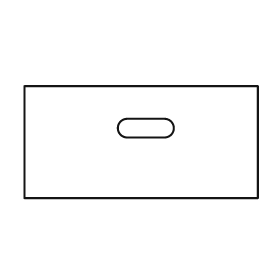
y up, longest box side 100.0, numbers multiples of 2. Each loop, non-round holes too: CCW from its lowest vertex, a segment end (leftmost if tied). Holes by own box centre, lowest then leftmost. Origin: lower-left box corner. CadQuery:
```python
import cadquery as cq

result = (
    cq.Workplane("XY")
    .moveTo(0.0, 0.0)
    .lineTo(100.0, 0.0)
    .lineTo(100.0, 48.0)
    .lineTo(0.0, 48.0)
    .close()
    .moveTo(44.0, 26.0)
    .lineTo(60.0, 26.0)
    .threePointArc((64.0, 30.0), (60.0, 34.0))
    .lineTo(44.0, 34.0)
    .threePointArc((40.0, 30.0), (44.0, 26.0))
    .close()
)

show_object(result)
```